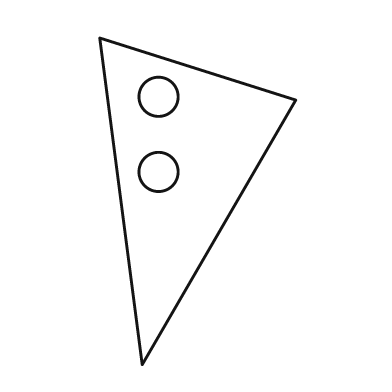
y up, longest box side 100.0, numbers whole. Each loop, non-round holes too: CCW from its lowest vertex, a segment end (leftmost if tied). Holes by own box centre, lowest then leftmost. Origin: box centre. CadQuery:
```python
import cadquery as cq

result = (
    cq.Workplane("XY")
    .moveTo(-17.0, -50.0)
    .lineTo(30.0, 31.0)
    .lineTo(-30.0, 50.0)
    .close()
    .moveTo(-12.0, 9.0)
    .circle(6.0)
    .moveTo(-12.0, 32.0)
    .circle(6.0)
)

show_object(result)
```